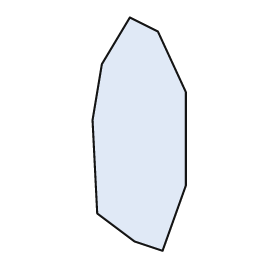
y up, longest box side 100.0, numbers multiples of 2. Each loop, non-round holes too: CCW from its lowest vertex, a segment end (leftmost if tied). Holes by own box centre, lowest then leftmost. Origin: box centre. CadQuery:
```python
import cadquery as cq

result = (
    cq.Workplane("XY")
    .moveTo(10.0, -50.0)
    .lineTo(20.0, -22.0)
    .lineTo(20.0, 18.0)
    .lineTo(8.0, 44.0)
    .lineTo(-4.0, 50.0)
    .lineTo(-16.0, 30.0)
    .lineTo(-20.0, 6.0)
    .lineTo(-18.0, -34.0)
    .lineTo(-2.0, -46.0)
    .close()
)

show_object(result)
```